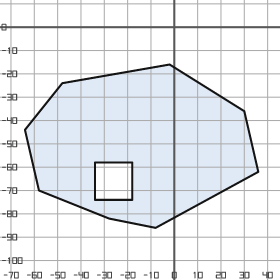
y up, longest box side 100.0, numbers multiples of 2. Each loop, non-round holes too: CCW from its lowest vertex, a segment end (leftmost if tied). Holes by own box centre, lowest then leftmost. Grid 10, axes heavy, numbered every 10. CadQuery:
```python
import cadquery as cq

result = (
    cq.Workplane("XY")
    .moveTo(-8.0, -86.0)
    .lineTo(36.0, -62.0)
    .lineTo(30.0, -36.0)
    .lineTo(-2.0, -16.0)
    .lineTo(-48.0, -24.0)
    .lineTo(-64.0, -44.0)
    .lineTo(-58.0, -70.0)
    .lineTo(-28.0, -82.0)
    .close()
    .moveTo(-34.0, -74.0)
    .lineTo(-18.0, -74.0)
    .lineTo(-18.0, -58.0)
    .lineTo(-34.0, -58.0)
    .close()
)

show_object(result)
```